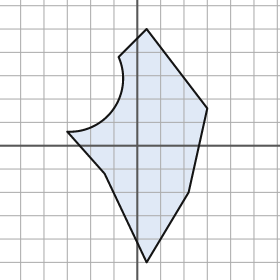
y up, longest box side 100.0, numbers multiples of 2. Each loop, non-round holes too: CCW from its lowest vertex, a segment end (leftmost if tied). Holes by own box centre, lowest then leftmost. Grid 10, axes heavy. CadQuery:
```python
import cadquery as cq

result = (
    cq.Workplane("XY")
    .moveTo(4.0, -50.0)
    .lineTo(22.0, -20.0)
    .lineTo(30.0, 16.0)
    .lineTo(4.0, 50.0)
    .lineTo(-8.0, 38.0)
    .threePointArc((-10.0, 16.0), (-30.0, 6.0))
    .lineTo(-14.0, -12.0)
    .close()
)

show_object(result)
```